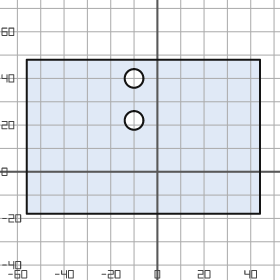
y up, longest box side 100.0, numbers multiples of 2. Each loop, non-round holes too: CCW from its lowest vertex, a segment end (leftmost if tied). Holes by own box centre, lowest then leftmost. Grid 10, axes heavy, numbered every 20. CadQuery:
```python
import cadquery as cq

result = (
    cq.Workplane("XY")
    .moveTo(-56.0, -18.0)
    .lineTo(44.0, -18.0)
    .lineTo(44.0, 48.0)
    .lineTo(-56.0, 48.0)
    .close()
    .moveTo(-10.0, 22.0)
    .circle(4.0)
    .moveTo(-10.0, 40.0)
    .circle(4.0)
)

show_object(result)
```